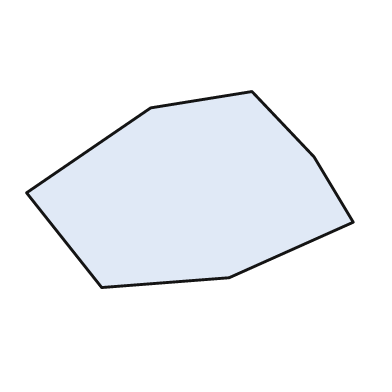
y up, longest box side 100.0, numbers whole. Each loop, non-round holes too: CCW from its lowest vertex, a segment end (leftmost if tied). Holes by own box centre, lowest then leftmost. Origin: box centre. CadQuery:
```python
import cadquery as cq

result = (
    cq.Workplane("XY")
    .moveTo(-27.0, -30.0)
    .lineTo(12.0, -27.0)
    .lineTo(50.0, -10.0)
    .lineTo(38.0, 10.0)
    .lineTo(19.0, 30.0)
    .lineTo(-12.0, 25.0)
    .lineTo(-50.0, -1.0)
    .close()
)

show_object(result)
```